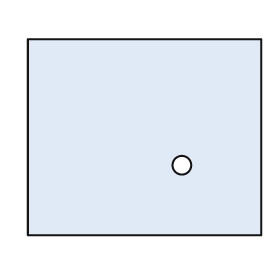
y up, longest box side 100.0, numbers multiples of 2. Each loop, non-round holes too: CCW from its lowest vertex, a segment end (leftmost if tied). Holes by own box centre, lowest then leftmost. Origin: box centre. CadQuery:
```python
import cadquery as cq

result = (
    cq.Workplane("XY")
    .moveTo(-50.0, -42.0)
    .lineTo(50.0, -42.0)
    .lineTo(50.0, 42.0)
    .lineTo(-50.0, 42.0)
    .close()
    .moveTo(16.0, -12.0)
    .circle(4.0)
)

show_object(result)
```